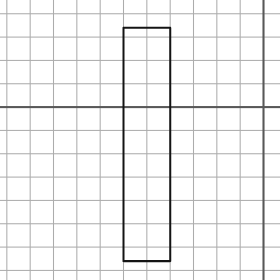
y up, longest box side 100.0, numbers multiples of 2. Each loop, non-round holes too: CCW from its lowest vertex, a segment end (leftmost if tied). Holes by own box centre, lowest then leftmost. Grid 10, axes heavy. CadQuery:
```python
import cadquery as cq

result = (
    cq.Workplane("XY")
    .moveTo(-60.0, -66.0)
    .lineTo(-40.0, -66.0)
    .lineTo(-40.0, 34.0)
    .lineTo(-60.0, 34.0)
    .close()
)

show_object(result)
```